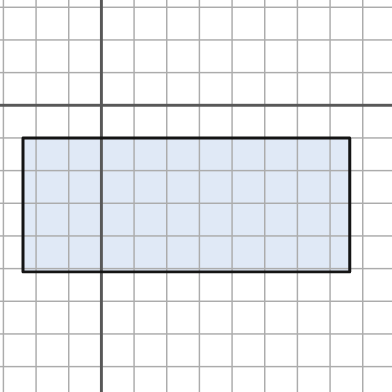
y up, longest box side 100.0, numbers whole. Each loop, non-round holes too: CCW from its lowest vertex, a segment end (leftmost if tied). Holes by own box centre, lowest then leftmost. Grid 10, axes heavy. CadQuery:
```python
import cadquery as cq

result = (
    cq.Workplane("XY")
    .moveTo(-24.0, -51.0)
    .lineTo(76.0, -51.0)
    .lineTo(76.0, -10.0)
    .lineTo(-24.0, -10.0)
    .close()
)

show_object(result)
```